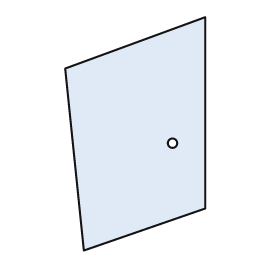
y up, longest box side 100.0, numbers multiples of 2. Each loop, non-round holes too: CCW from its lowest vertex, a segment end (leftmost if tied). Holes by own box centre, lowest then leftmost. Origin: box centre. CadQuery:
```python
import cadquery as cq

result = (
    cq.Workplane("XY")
    .moveTo(-22.0, -50.0)
    .lineTo(30.0, -32.0)
    .lineTo(30.0, 50.0)
    .lineTo(-30.0, 28.0)
    .close()
    .moveTo(16.0, -4.0)
    .circle(2.0)
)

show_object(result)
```